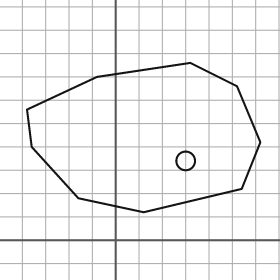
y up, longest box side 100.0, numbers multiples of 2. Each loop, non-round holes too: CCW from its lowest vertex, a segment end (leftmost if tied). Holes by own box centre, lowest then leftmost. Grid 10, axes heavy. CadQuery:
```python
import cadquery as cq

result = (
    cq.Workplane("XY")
    .moveTo(12.0, 12.0)
    .lineTo(54.0, 22.0)
    .lineTo(62.0, 42.0)
    .lineTo(52.0, 66.0)
    .lineTo(32.0, 76.0)
    .lineTo(-8.0, 70.0)
    .lineTo(-38.0, 56.0)
    .lineTo(-36.0, 40.0)
    .lineTo(-16.0, 18.0)
    .close()
    .moveTo(30.0, 34.0)
    .circle(4.0)
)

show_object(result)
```